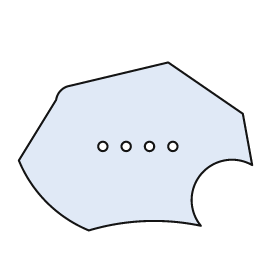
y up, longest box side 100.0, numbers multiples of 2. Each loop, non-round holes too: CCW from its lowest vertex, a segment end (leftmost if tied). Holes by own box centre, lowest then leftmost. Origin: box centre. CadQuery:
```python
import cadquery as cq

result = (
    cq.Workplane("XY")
    .moveTo(-20.0, -36.0)
    .threePointArc((4.0, -32.0), (28.0, -34.0))
    .threePointArc((28.0, -12.0), (50.0, -8.0))
    .lineTo(46.0, 14.0)
    .lineTo(14.0, 36.0)
    .lineTo(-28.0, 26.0)
    .threePointArc((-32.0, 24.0), (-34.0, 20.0))
    .lineTo(-50.0, -6.0)
    .threePointArc((-38.0, -24.0), (-20.0, -36.0))
    .close()
    .moveTo(-14.0, 0.0)
    .circle(2.0)
    .moveTo(-4.0, 0.0)
    .circle(2.0)
    .moveTo(6.0, 0.0)
    .circle(2.0)
    .moveTo(16.0, 0.0)
    .circle(2.0)
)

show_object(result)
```